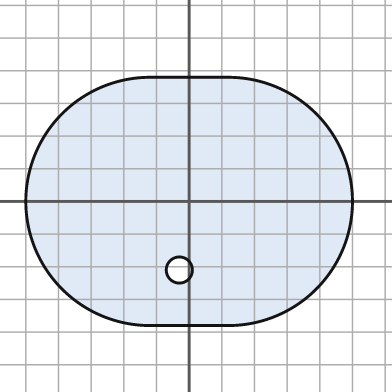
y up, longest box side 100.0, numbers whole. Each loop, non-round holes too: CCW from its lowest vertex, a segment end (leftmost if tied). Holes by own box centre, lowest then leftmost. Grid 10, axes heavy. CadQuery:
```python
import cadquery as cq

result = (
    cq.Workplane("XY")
    .moveTo(-12.0, -38.0)
    .lineTo(12.0, -38.0)
    .threePointArc((50.0, 0.0), (12.0, 38.0))
    .lineTo(-12.0, 38.0)
    .threePointArc((-50.0, 0.0), (-12.0, -38.0))
    .close()
    .moveTo(-3.0, -21.0)
    .circle(4.0)
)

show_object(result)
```